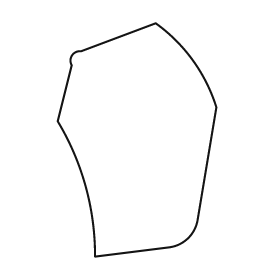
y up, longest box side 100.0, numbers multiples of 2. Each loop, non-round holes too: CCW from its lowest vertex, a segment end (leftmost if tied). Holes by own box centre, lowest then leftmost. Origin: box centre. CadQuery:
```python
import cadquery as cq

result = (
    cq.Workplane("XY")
    .moveTo(-18.0, -50.0)
    .lineTo(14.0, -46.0)
    .threePointArc((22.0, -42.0), (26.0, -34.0))
    .lineTo(34.0, 14.0)
    .threePointArc((24.0, 34.0), (8.0, 50.0))
    .lineTo(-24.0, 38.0)
    .threePointArc((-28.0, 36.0), (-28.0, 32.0))
    .lineTo(-34.0, 8.0)
    .threePointArc((-22.0, -20.0), (-18.0, -50.0))
    .close()
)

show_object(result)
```